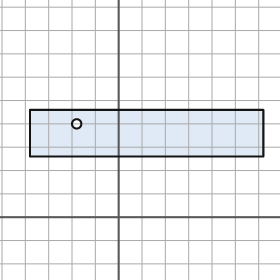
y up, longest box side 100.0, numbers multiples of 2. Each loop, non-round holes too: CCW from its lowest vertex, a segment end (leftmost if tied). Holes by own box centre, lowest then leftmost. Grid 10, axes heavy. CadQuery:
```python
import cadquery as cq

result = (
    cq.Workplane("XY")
    .moveTo(-38.0, 26.0)
    .lineTo(62.0, 26.0)
    .lineTo(62.0, 46.0)
    .lineTo(-38.0, 46.0)
    .close()
    .moveTo(-18.0, 40.0)
    .circle(2.0)
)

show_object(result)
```